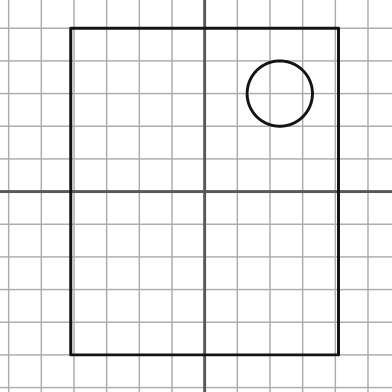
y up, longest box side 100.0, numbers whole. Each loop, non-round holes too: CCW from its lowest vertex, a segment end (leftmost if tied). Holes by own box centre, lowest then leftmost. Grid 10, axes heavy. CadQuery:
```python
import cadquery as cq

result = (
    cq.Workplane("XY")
    .moveTo(-41.0, -50.0)
    .lineTo(41.0, -50.0)
    .lineTo(41.0, 50.0)
    .lineTo(-41.0, 50.0)
    .close()
    .moveTo(23.0, 30.0)
    .circle(10.0)
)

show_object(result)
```